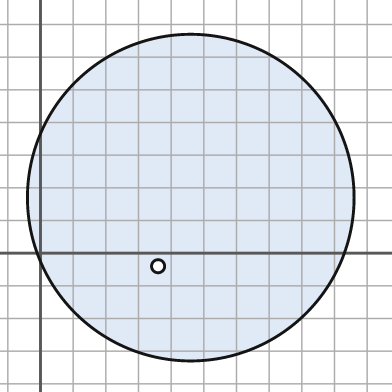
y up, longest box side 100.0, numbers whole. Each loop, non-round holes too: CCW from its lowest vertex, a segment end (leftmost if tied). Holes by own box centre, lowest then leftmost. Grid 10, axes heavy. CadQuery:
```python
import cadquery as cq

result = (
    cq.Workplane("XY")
    .moveTo(46.0, 17.0)
    .circle(50.0)
    .moveTo(36.0, -4.0)
    .circle(2.0)
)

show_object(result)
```